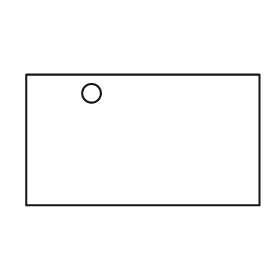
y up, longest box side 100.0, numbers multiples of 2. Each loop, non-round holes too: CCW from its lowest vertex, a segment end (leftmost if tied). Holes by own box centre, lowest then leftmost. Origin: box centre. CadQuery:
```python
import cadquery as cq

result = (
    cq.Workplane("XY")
    .moveTo(-50.0, -28.0)
    .lineTo(50.0, -28.0)
    .lineTo(50.0, 28.0)
    .lineTo(-50.0, 28.0)
    .close()
    .moveTo(-22.0, 20.0)
    .circle(4.0)
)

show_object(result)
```